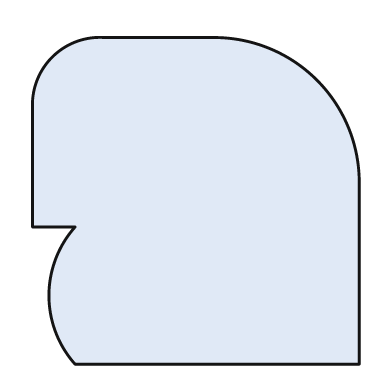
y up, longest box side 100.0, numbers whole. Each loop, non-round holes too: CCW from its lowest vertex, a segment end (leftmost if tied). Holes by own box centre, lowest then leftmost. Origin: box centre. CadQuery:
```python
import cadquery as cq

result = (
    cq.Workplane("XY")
    .moveTo(-37.0, -50.0)
    .lineTo(50.0, -50.0)
    .lineTo(50.0, 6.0)
    .threePointArc((37.0, 37.0), (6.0, 50.0))
    .lineTo(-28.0, 50.0)
    .threePointArc((-44.0, 44.0), (-50.0, 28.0))
    .lineTo(-50.0, -8.0)
    .lineTo(-37.0, -8.0)
    .threePointArc((-45.0, -29.0), (-37.0, -50.0))
    .close()
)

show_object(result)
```